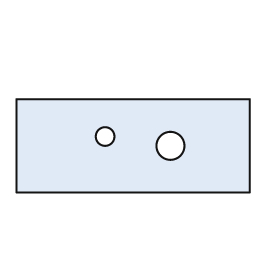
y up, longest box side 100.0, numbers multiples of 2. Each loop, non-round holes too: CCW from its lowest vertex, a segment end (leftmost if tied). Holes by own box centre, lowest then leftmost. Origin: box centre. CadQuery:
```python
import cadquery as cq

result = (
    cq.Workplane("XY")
    .moveTo(-50.0, -20.0)
    .lineTo(50.0, -20.0)
    .lineTo(50.0, 20.0)
    .lineTo(-50.0, 20.0)
    .close()
    .moveTo(16.0, 0.0)
    .circle(6.0)
    .moveTo(-12.0, 4.0)
    .circle(4.0)
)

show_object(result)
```